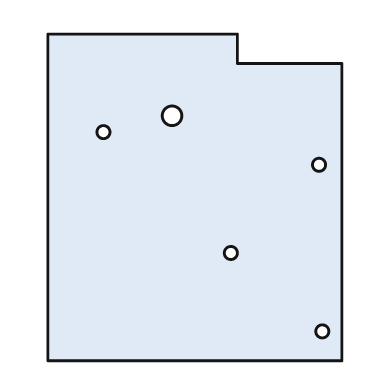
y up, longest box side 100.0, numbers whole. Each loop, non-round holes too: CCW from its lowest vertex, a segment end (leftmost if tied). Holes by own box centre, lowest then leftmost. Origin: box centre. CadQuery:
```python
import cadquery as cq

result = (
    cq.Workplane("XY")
    .moveTo(-45.0, -50.0)
    .lineTo(45.0, -50.0)
    .lineTo(45.0, 41.0)
    .lineTo(13.0, 41.0)
    .lineTo(13.0, 50.0)
    .lineTo(-45.0, 50.0)
    .close()
    .moveTo(39.0, -41.0)
    .circle(2.0)
    .moveTo(11.0, -17.0)
    .circle(2.0)
    .moveTo(38.0, 10.0)
    .circle(2.0)
    .moveTo(-28.0, 20.0)
    .circle(2.0)
    .moveTo(-7.0, 25.0)
    .circle(3.0)
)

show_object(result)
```